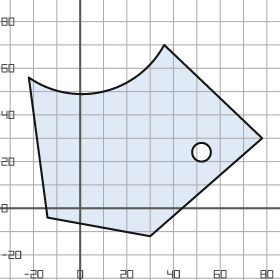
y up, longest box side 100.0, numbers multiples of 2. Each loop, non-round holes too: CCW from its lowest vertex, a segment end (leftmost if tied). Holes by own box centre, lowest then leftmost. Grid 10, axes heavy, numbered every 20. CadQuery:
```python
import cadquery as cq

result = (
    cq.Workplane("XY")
    .moveTo(30.0, -12.0)
    .lineTo(78.0, 30.0)
    .lineTo(36.0, 70.0)
    .threePointArc((10.0, 50.0), (-22.0, 56.0))
    .lineTo(-14.0, -4.0)
    .close()
    .moveTo(52.0, 24.0)
    .circle(4.0)
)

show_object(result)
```